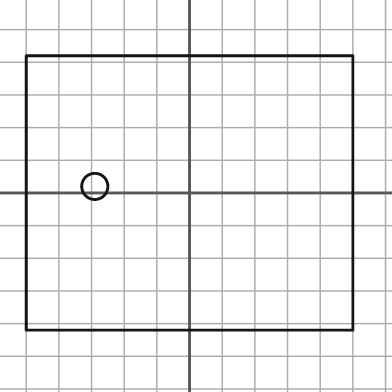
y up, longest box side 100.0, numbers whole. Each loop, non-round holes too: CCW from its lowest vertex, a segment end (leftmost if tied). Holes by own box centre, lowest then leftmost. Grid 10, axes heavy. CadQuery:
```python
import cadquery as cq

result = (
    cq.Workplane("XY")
    .moveTo(-50.0, -42.0)
    .lineTo(50.0, -42.0)
    .lineTo(50.0, 42.0)
    .lineTo(-50.0, 42.0)
    .close()
    .moveTo(-29.0, 2.0)
    .circle(4.0)
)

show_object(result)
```